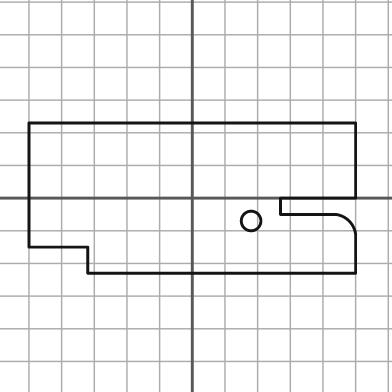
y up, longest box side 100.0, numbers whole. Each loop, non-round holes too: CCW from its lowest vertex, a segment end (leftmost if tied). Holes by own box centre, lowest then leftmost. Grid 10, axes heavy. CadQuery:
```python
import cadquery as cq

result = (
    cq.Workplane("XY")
    .moveTo(-32.0, -23.0)
    .lineTo(50.0, -23.0)
    .lineTo(50.0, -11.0)
    .threePointArc((48.0, -7.0), (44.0, -5.0))
    .lineTo(27.0, -5.0)
    .lineTo(27.0, 0.0)
    .lineTo(50.0, 0.0)
    .lineTo(50.0, 23.0)
    .lineTo(-50.0, 23.0)
    .lineTo(-50.0, -15.0)
    .lineTo(-32.0, -15.0)
    .close()
    .moveTo(18.0, -7.0)
    .circle(3.0)
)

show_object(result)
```